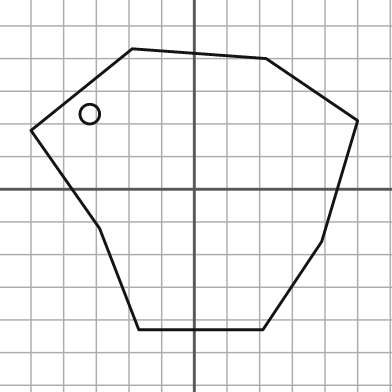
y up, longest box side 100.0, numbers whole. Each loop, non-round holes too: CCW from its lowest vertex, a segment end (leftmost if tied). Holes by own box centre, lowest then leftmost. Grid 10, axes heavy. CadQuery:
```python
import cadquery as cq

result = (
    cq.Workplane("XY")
    .moveTo(-17.0, -43.0)
    .lineTo(21.0, -43.0)
    .lineTo(39.0, -16.0)
    .lineTo(50.0, 21.0)
    .lineTo(22.0, 40.0)
    .lineTo(-19.0, 43.0)
    .lineTo(-50.0, 18.0)
    .lineTo(-29.0, -12.0)
    .close()
    .moveTo(-32.0, 23.0)
    .circle(3.0)
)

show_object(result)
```